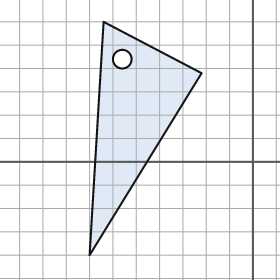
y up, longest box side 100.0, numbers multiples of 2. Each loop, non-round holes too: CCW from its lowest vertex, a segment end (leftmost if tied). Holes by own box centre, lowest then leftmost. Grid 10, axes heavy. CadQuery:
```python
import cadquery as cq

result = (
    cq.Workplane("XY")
    .moveTo(-70.0, -40.0)
    .lineTo(-22.0, 38.0)
    .lineTo(-64.0, 60.0)
    .close()
    .moveTo(-56.0, 44.0)
    .circle(4.0)
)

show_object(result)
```